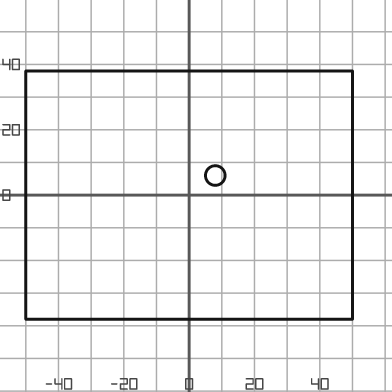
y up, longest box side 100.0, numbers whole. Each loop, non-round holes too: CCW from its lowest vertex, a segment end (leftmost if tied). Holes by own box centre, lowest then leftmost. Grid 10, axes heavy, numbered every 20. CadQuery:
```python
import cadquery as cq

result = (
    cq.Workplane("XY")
    .moveTo(-50.0, -38.0)
    .lineTo(50.0, -38.0)
    .lineTo(50.0, 38.0)
    .lineTo(-50.0, 38.0)
    .close()
    .moveTo(8.0, 6.0)
    .circle(3.0)
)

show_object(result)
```